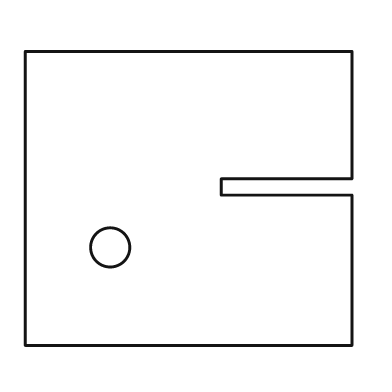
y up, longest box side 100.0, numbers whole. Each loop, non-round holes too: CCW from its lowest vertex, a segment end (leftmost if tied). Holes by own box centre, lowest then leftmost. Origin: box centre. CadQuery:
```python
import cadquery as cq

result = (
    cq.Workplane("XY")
    .moveTo(-50.0, -45.0)
    .lineTo(50.0, -45.0)
    .lineTo(50.0, 1.0)
    .lineTo(10.0, 1.0)
    .lineTo(10.0, 6.0)
    .lineTo(50.0, 6.0)
    .lineTo(50.0, 45.0)
    .lineTo(-50.0, 45.0)
    .close()
    .moveTo(-24.0, -15.0)
    .circle(6.0)
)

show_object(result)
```